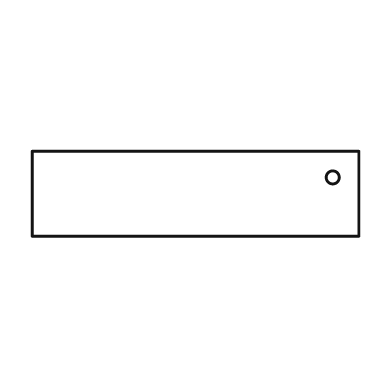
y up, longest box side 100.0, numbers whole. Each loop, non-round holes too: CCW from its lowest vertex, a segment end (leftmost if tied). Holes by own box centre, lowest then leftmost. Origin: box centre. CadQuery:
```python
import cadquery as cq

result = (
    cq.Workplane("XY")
    .moveTo(-50.0, -13.0)
    .lineTo(50.0, -13.0)
    .lineTo(50.0, 13.0)
    .lineTo(-50.0, 13.0)
    .close()
    .moveTo(42.0, 5.0)
    .circle(2.0)
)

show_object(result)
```